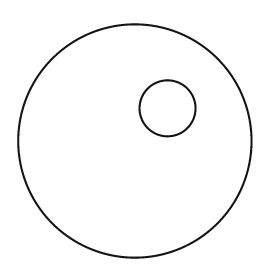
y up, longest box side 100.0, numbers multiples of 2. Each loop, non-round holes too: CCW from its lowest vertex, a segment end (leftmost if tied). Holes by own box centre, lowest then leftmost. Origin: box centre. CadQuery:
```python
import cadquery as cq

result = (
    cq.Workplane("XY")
    .moveTo(0.0, 0.0)
    .circle(50.0)
    .moveTo(14.0, 14.0)
    .circle(12.0)
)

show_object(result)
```